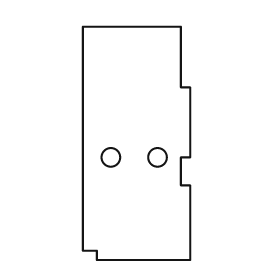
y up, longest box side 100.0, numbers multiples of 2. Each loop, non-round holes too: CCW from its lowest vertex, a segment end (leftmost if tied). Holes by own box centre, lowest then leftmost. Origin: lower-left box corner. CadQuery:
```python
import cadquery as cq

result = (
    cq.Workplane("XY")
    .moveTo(6.0, 0.0)
    .lineTo(46.0, 0.0)
    .lineTo(46.0, 32.0)
    .lineTo(42.0, 32.0)
    .lineTo(42.0, 44.0)
    .lineTo(46.0, 44.0)
    .lineTo(46.0, 74.0)
    .lineTo(42.0, 74.0)
    .lineTo(42.0, 100.0)
    .lineTo(0.0, 100.0)
    .lineTo(0.0, 4.0)
    .lineTo(6.0, 4.0)
    .close()
    .moveTo(12.0, 44.0)
    .circle(4.0)
    .moveTo(32.0, 44.0)
    .circle(4.0)
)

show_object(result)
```